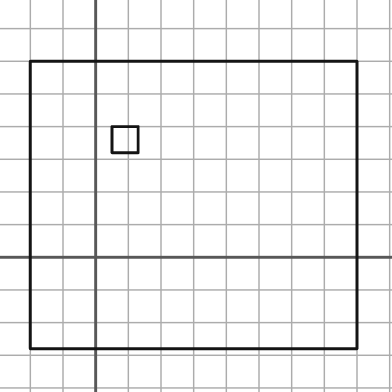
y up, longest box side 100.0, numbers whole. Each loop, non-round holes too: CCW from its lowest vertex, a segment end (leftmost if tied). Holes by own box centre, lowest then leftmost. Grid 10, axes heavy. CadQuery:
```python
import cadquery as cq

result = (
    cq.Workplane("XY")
    .moveTo(-20.0, -28.0)
    .lineTo(80.0, -28.0)
    .lineTo(80.0, 60.0)
    .lineTo(-20.0, 60.0)
    .close()
    .moveTo(5.0, 32.0)
    .lineTo(13.0, 32.0)
    .lineTo(13.0, 40.0)
    .lineTo(5.0, 40.0)
    .close()
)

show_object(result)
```